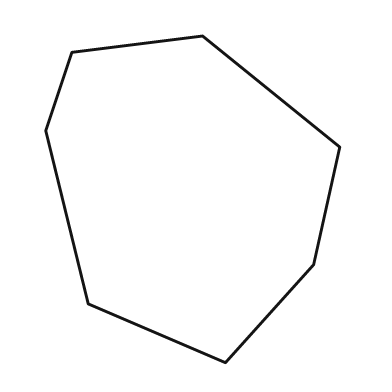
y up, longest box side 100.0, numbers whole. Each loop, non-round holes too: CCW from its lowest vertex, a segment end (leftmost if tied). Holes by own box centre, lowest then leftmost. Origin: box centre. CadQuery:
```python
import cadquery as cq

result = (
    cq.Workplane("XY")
    .moveTo(10.0, -50.0)
    .lineTo(37.0, -20.0)
    .lineTo(45.0, 16.0)
    .lineTo(3.0, 50.0)
    .lineTo(-37.0, 45.0)
    .lineTo(-45.0, 21.0)
    .lineTo(-32.0, -32.0)
    .close()
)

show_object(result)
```